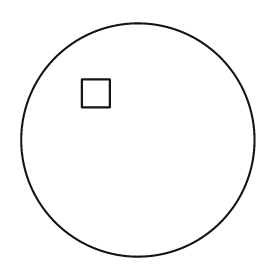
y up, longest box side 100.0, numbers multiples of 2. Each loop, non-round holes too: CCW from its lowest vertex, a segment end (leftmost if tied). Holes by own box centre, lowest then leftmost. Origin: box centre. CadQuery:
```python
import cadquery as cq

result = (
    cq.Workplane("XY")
    .moveTo(0.0, 0.0)
    .circle(50.0)
    .moveTo(-24.0, 14.0)
    .lineTo(-12.0, 14.0)
    .lineTo(-12.0, 26.0)
    .lineTo(-24.0, 26.0)
    .close()
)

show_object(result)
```